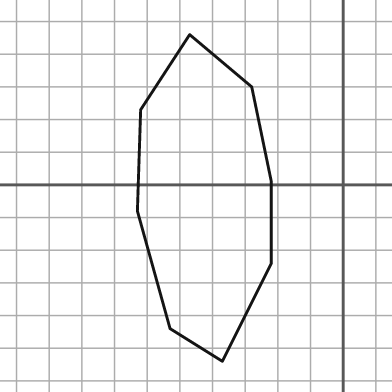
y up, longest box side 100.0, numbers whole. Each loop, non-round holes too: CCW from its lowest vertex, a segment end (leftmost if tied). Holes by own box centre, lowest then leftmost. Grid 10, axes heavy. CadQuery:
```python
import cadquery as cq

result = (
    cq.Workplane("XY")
    .moveTo(-37.0, -54.0)
    .lineTo(-22.0, -24.0)
    .lineTo(-22.0, 1.0)
    .lineTo(-28.0, 30.0)
    .lineTo(-47.0, 46.0)
    .lineTo(-62.0, 23.0)
    .lineTo(-63.0, -8.0)
    .lineTo(-53.0, -44.0)
    .close()
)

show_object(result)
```